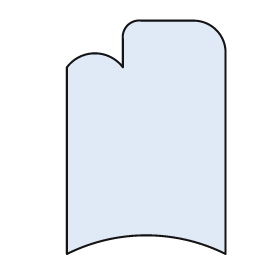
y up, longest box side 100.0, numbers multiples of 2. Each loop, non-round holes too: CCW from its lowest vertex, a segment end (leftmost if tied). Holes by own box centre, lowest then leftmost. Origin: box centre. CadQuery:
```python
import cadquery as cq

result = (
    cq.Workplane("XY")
    .moveTo(-34.0, -50.0)
    .threePointArc((0.0, -42.0), (34.0, -50.0))
    .lineTo(34.0, 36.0)
    .threePointArc((30.0, 46.0), (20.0, 50.0))
    .lineTo(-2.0, 50.0)
    .threePointArc((-8.0, 48.0), (-10.0, 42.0))
    .lineTo(-10.0, 30.0)
    .threePointArc((-22.0, 36.0), (-34.0, 30.0))
    .close()
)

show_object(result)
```